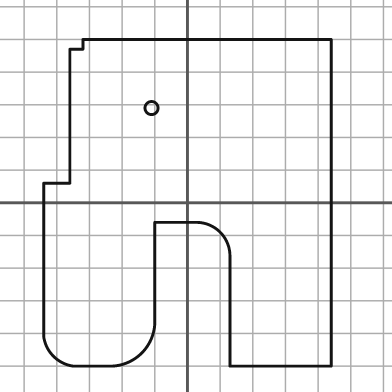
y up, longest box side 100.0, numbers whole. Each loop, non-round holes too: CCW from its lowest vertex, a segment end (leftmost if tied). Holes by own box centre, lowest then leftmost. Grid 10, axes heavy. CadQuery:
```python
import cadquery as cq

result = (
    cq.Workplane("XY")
    .moveTo(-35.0, -50.0)
    .lineTo(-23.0, -50.0)
    .threePointArc((-14.0, -46.0), (-10.0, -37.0))
    .lineTo(-10.0, -6.0)
    .lineTo(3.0, -6.0)
    .threePointArc((10.0, -9.0), (13.0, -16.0))
    .lineTo(13.0, -50.0)
    .lineTo(44.0, -50.0)
    .lineTo(44.0, 50.0)
    .lineTo(-32.0, 50.0)
    .lineTo(-32.0, 47.0)
    .lineTo(-36.0, 47.0)
    .lineTo(-36.0, 6.0)
    .lineTo(-44.0, 6.0)
    .lineTo(-44.0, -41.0)
    .threePointArc((-41.0, -47.0), (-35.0, -50.0))
    .close()
    .moveTo(-11.0, 29.0)
    .circle(2.0)
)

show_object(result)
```